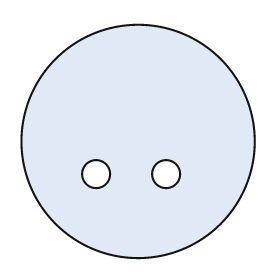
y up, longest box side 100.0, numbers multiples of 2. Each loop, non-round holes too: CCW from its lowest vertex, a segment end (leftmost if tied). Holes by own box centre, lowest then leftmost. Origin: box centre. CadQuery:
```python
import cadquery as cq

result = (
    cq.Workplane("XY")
    .moveTo(0.0, 0.0)
    .circle(50.0)
    .moveTo(-18.0, -14.0)
    .circle(6.0)
    .moveTo(12.0, -14.0)
    .circle(6.0)
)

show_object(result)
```